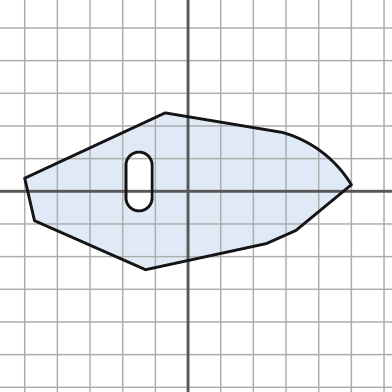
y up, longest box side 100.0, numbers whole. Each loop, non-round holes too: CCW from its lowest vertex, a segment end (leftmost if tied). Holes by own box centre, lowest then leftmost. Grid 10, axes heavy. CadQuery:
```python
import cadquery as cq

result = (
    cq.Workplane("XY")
    .moveTo(-13.0, -24.0)
    .lineTo(24.0, -16.0)
    .lineTo(33.0, -12.0)
    .lineTo(50.0, 2.0)
    .threePointArc((41.0, 12.0), (29.0, 18.0))
    .lineTo(-7.0, 24.0)
    .lineTo(-50.0, 4.0)
    .lineTo(-47.0, -9.0)
    .close()
    .moveTo(-19.0, -2.0)
    .threePointArc((-15.0, -6.0), (-11.0, -2.0))
    .lineTo(-11.0, 8.0)
    .threePointArc((-15.0, 12.0), (-19.0, 8.0))
    .close()
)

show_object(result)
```